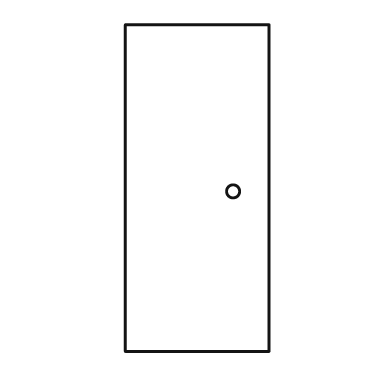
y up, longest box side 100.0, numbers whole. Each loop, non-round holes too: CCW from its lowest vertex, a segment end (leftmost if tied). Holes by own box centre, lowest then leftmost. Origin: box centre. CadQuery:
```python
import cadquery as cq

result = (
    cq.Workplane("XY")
    .moveTo(-22.0, -50.0)
    .lineTo(22.0, -50.0)
    .lineTo(22.0, 50.0)
    .lineTo(-22.0, 50.0)
    .close()
    .moveTo(11.0, -1.0)
    .circle(2.0)
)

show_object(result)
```